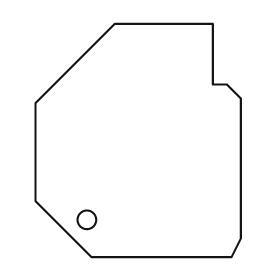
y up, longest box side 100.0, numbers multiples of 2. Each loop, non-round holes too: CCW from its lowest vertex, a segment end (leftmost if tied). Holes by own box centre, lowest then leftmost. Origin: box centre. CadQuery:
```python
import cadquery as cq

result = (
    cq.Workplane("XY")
    .moveTo(-20.0, -50.0)
    .lineTo(40.0, -50.0)
    .lineTo(44.0, -42.0)
    .lineTo(44.0, 18.0)
    .lineTo(38.0, 24.0)
    .lineTo(32.0, 24.0)
    .lineTo(32.0, 50.0)
    .lineTo(-10.0, 50.0)
    .lineTo(-44.0, 16.0)
    .lineTo(-44.0, -26.0)
    .close()
    .moveTo(-22.0, -34.0)
    .circle(4.0)
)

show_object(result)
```